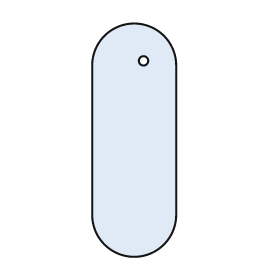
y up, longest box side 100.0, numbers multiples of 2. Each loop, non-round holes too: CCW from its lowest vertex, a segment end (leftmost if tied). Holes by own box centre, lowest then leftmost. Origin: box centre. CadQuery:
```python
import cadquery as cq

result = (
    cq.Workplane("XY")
    .moveTo(-18.0, -32.0)
    .threePointArc((0.0, -50.0), (18.0, -32.0))
    .lineTo(18.0, 32.0)
    .threePointArc((0.0, 50.0), (-18.0, 32.0))
    .close()
    .moveTo(4.0, 34.0)
    .circle(2.0)
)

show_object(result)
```